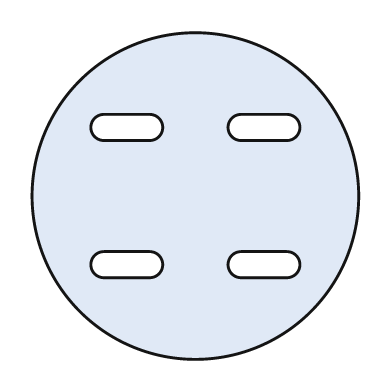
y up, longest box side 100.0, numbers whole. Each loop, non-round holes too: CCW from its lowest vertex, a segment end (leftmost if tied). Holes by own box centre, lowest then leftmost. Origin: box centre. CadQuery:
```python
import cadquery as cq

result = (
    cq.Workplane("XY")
    .moveTo(0.0, 0.0)
    .circle(50.0)
    .moveTo(-28.0, -25.0)
    .lineTo(-14.0, -25.0)
    .threePointArc((-10.0, -21.0), (-14.0, -17.0))
    .lineTo(-28.0, -17.0)
    .threePointArc((-32.0, -21.0), (-28.0, -25.0))
    .close()
    .moveTo(14.0, -25.0)
    .lineTo(28.0, -25.0)
    .threePointArc((32.0, -21.0), (28.0, -17.0))
    .lineTo(14.0, -17.0)
    .threePointArc((10.0, -21.0), (14.0, -25.0))
    .close()
    .moveTo(-28.0, 17.0)
    .lineTo(-14.0, 17.0)
    .threePointArc((-10.0, 21.0), (-14.0, 25.0))
    .lineTo(-28.0, 25.0)
    .threePointArc((-32.0, 21.0), (-28.0, 17.0))
    .close()
    .moveTo(14.0, 17.0)
    .lineTo(28.0, 17.0)
    .threePointArc((32.0, 21.0), (28.0, 25.0))
    .lineTo(14.0, 25.0)
    .threePointArc((10.0, 21.0), (14.0, 17.0))
    .close()
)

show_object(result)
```